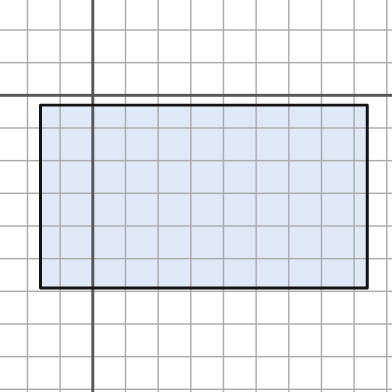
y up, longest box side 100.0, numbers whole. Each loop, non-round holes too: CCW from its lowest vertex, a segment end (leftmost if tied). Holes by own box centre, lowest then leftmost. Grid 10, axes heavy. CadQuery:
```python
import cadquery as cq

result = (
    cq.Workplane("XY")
    .moveTo(-16.0, -59.0)
    .lineTo(84.0, -59.0)
    .lineTo(84.0, -3.0)
    .lineTo(-16.0, -3.0)
    .close()
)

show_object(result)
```